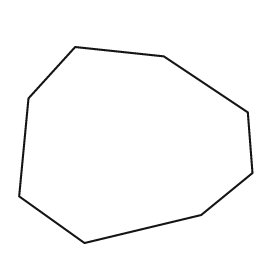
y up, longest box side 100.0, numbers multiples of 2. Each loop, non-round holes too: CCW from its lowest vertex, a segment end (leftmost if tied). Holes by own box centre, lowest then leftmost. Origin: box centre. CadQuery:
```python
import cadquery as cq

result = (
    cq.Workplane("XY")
    .moveTo(-22.0, -42.0)
    .lineTo(28.0, -30.0)
    .lineTo(50.0, -12.0)
    .lineTo(48.0, 14.0)
    .lineTo(12.0, 38.0)
    .lineTo(-26.0, 42.0)
    .lineTo(-46.0, 20.0)
    .lineTo(-50.0, -22.0)
    .close()
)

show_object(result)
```